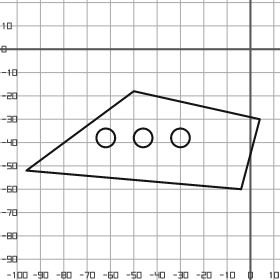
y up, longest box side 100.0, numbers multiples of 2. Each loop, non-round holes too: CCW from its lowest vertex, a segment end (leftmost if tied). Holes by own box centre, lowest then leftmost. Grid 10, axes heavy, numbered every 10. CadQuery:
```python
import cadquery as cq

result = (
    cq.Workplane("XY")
    .moveTo(-4.0, -60.0)
    .lineTo(4.0, -30.0)
    .lineTo(-50.0, -18.0)
    .lineTo(-96.0, -52.0)
    .close()
    .moveTo(-62.0, -38.0)
    .circle(4.0)
    .moveTo(-46.0, -38.0)
    .circle(4.0)
    .moveTo(-30.0, -38.0)
    .circle(4.0)
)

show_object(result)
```